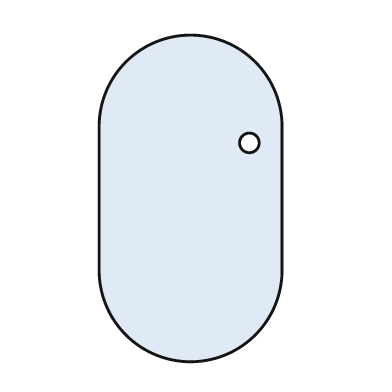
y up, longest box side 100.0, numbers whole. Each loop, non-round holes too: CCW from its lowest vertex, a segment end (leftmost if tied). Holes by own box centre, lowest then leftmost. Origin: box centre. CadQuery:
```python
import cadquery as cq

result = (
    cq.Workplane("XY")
    .moveTo(-28.0, -22.0)
    .threePointArc((0.0, -50.0), (28.0, -22.0))
    .lineTo(28.0, 22.0)
    .threePointArc((0.0, 50.0), (-28.0, 22.0))
    .close()
    .moveTo(18.0, 17.0)
    .circle(3.0)
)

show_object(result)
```